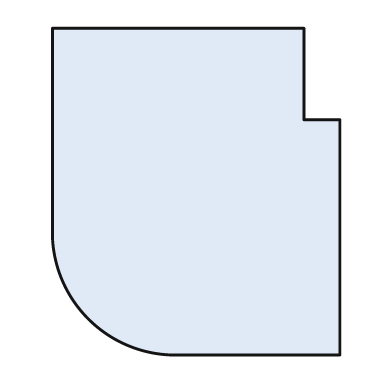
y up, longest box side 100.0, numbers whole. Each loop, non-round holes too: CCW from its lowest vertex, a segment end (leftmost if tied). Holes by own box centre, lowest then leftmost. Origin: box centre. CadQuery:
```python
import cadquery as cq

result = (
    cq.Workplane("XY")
    .moveTo(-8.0, -50.0)
    .lineTo(44.0, -50.0)
    .lineTo(44.0, 22.0)
    .lineTo(33.0, 22.0)
    .lineTo(33.0, 50.0)
    .lineTo(-44.0, 50.0)
    .lineTo(-44.0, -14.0)
    .threePointArc((-33.0, -39.0), (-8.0, -50.0))
    .close()
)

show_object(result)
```